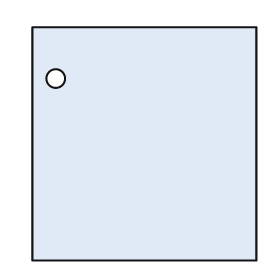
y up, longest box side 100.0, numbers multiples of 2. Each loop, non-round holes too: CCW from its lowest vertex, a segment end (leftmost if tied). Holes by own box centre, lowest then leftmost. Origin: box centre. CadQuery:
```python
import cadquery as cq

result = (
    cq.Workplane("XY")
    .moveTo(-48.0, -50.0)
    .lineTo(48.0, -50.0)
    .lineTo(48.0, 50.0)
    .lineTo(-48.0, 50.0)
    .close()
    .moveTo(-38.0, 28.0)
    .circle(4.0)
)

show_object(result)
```